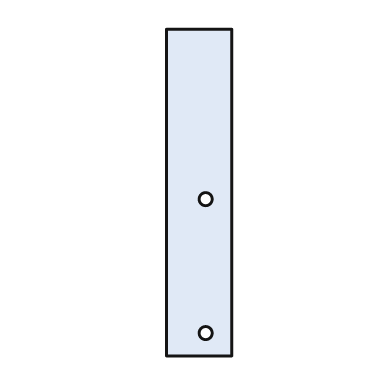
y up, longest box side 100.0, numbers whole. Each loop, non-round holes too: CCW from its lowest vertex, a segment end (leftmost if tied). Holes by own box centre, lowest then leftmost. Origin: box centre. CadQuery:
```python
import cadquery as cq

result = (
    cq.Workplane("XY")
    .moveTo(-10.0, -50.0)
    .lineTo(10.0, -50.0)
    .lineTo(10.0, 50.0)
    .lineTo(-10.0, 50.0)
    .close()
    .moveTo(2.0, -43.0)
    .circle(2.0)
    .moveTo(2.0, -2.0)
    .circle(2.0)
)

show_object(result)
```